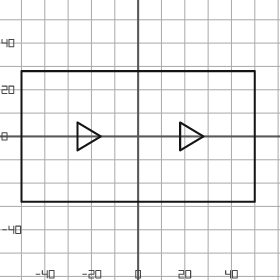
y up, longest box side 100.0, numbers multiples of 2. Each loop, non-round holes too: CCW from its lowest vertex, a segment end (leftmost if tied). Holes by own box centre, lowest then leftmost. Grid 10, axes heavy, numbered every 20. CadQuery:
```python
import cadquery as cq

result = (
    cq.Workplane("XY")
    .moveTo(-50.0, -28.0)
    .lineTo(50.0, -28.0)
    .lineTo(50.0, 28.0)
    .lineTo(-50.0, 28.0)
    .close()
    .moveTo(-26.0, -6.0)
    .lineTo(-16.0, 0.0)
    .lineTo(-26.0, 6.0)
    .close()
    .moveTo(18.0, -6.0)
    .lineTo(28.0, 0.0)
    .lineTo(18.0, 6.0)
    .close()
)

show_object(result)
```